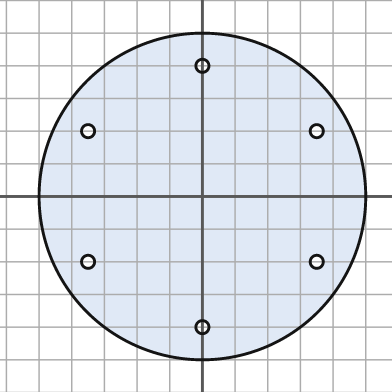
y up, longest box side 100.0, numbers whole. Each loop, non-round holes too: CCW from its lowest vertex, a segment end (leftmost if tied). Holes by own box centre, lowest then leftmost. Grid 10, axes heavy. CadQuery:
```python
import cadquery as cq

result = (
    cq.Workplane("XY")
    .moveTo(0.0, 0.0)
    .circle(50.0)
    .moveTo(0.0, -40.0)
    .circle(2.0)
    .moveTo(-35.0, -20.0)
    .circle(2.0)
    .moveTo(35.0, -20.0)
    .circle(2.0)
    .moveTo(-35.0, 20.0)
    .circle(2.0)
    .moveTo(35.0, 20.0)
    .circle(2.0)
    .moveTo(0.0, 40.0)
    .circle(2.0)
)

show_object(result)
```